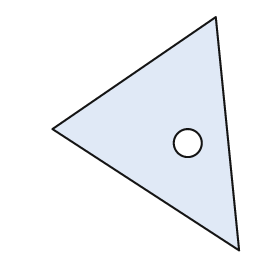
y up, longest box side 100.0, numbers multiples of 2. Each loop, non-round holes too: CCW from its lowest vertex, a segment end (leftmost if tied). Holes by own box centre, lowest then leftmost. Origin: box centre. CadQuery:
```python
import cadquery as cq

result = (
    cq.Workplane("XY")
    .moveTo(40.0, -50.0)
    .lineTo(30.0, 50.0)
    .lineTo(-40.0, 2.0)
    .close()
    .moveTo(18.0, -4.0)
    .circle(6.0)
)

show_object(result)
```